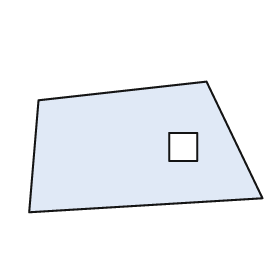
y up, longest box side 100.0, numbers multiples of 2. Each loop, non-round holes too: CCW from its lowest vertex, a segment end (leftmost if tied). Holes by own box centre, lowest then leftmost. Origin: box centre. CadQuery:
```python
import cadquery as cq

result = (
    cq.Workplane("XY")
    .moveTo(-50.0, -28.0)
    .lineTo(50.0, -22.0)
    .lineTo(26.0, 28.0)
    .lineTo(-46.0, 20.0)
    .close()
    .moveTo(10.0, -6.0)
    .lineTo(22.0, -6.0)
    .lineTo(22.0, 6.0)
    .lineTo(10.0, 6.0)
    .close()
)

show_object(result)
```